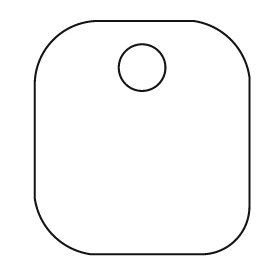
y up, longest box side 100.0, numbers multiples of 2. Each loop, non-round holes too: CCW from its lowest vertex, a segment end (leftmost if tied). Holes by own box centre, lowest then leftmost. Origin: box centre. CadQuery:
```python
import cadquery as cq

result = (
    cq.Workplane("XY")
    .moveTo(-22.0, -50.0)
    .lineTo(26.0, -50.0)
    .threePointArc((40.0, -44.0), (46.0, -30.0))
    .lineTo(46.0, 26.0)
    .threePointArc((38.0, 42.0), (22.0, 50.0))
    .lineTo(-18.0, 50.0)
    .threePointArc((-38.0, 42.0), (-46.0, 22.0))
    .lineTo(-46.0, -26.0)
    .threePointArc((-38.0, -42.0), (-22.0, -50.0))
    .close()
    .moveTo(0.0, 30.0)
    .circle(10.0)
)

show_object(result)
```